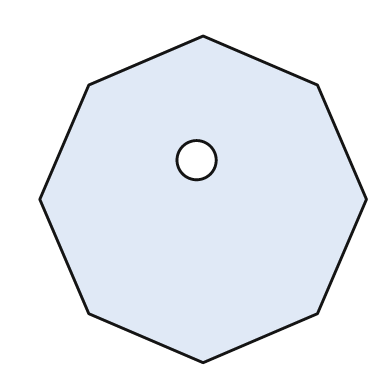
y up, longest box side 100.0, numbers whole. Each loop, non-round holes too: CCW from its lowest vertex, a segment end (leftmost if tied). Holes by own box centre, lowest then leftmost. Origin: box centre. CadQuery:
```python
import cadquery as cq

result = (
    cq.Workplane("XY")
    .moveTo(0.0, -50.0)
    .lineTo(35.0, -35.0)
    .lineTo(50.0, 0.0)
    .lineTo(35.0, 35.0)
    .lineTo(0.0, 50.0)
    .lineTo(-35.0, 35.0)
    .lineTo(-50.0, 0.0)
    .lineTo(-35.0, -35.0)
    .close()
    .moveTo(-2.0, 12.0)
    .circle(6.0)
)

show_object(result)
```